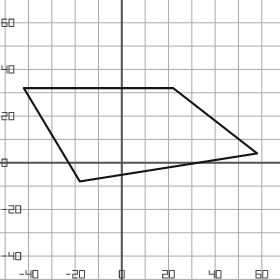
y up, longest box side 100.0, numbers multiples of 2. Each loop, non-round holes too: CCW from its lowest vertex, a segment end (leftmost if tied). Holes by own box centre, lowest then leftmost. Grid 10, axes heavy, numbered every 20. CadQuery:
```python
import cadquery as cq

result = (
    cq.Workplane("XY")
    .moveTo(-18.0, -8.0)
    .lineTo(58.0, 4.0)
    .lineTo(22.0, 32.0)
    .lineTo(-42.0, 32.0)
    .close()
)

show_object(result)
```